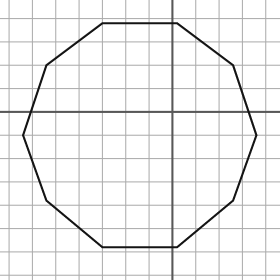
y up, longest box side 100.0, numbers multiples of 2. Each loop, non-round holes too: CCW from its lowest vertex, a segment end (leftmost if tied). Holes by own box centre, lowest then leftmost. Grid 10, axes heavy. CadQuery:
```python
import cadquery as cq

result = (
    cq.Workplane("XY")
    .moveTo(-30.0, -58.0)
    .lineTo(2.0, -58.0)
    .lineTo(26.0, -38.0)
    .lineTo(36.0, -10.0)
    .lineTo(26.0, 20.0)
    .lineTo(2.0, 38.0)
    .lineTo(-30.0, 38.0)
    .lineTo(-54.0, 20.0)
    .lineTo(-64.0, -10.0)
    .lineTo(-54.0, -38.0)
    .close()
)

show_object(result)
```